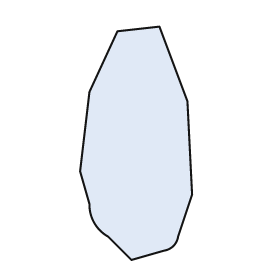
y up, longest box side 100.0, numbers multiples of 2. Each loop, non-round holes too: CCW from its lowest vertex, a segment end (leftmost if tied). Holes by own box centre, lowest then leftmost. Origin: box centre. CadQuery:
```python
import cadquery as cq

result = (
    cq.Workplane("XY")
    .moveTo(-2.0, -50.0)
    .lineTo(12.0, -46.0)
    .threePointArc((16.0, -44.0), (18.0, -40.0))
    .lineTo(24.0, -22.0)
    .lineTo(22.0, 18.0)
    .lineTo(10.0, 50.0)
    .lineTo(-8.0, 48.0)
    .lineTo(-20.0, 22.0)
    .lineTo(-24.0, -12.0)
    .lineTo(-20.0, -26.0)
    .threePointArc((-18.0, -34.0), (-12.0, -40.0))
    .close()
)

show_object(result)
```